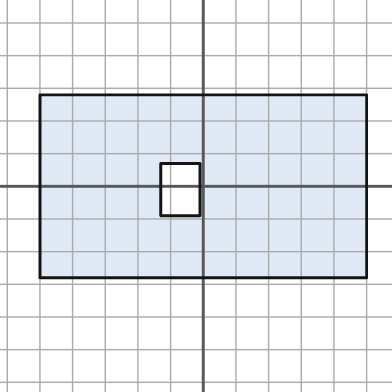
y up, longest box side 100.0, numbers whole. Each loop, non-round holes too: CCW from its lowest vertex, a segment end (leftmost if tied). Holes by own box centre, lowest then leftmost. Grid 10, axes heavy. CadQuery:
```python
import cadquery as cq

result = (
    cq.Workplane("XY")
    .moveTo(-50.0, -28.0)
    .lineTo(50.0, -28.0)
    .lineTo(50.0, 28.0)
    .lineTo(-50.0, 28.0)
    .close()
    .moveTo(-13.0, -9.0)
    .lineTo(-1.0, -9.0)
    .lineTo(-1.0, 7.0)
    .lineTo(-13.0, 7.0)
    .close()
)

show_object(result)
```